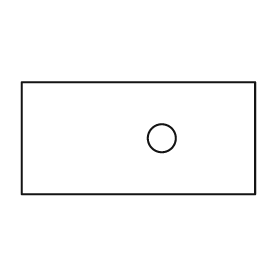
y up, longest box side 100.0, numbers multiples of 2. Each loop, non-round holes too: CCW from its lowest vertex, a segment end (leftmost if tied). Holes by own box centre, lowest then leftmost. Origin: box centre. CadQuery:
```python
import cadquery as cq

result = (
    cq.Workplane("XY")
    .moveTo(-50.0, -24.0)
    .lineTo(50.0, -24.0)
    .lineTo(50.0, 24.0)
    .lineTo(-50.0, 24.0)
    .close()
    .moveTo(10.0, 0.0)
    .circle(6.0)
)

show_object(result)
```